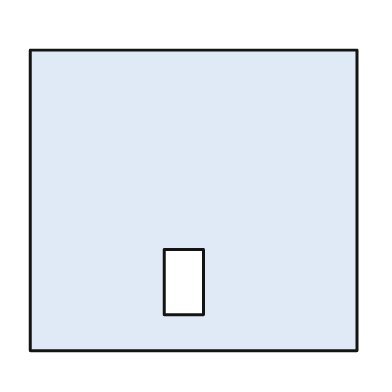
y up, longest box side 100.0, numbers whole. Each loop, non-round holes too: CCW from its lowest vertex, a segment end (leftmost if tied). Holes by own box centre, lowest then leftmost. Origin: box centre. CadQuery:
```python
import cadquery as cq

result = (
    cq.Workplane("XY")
    .moveTo(-50.0, -46.0)
    .lineTo(50.0, -46.0)
    .lineTo(50.0, 46.0)
    .lineTo(-50.0, 46.0)
    .close()
    .moveTo(-9.0, -35.0)
    .lineTo(3.0, -35.0)
    .lineTo(3.0, -15.0)
    .lineTo(-9.0, -15.0)
    .close()
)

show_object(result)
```